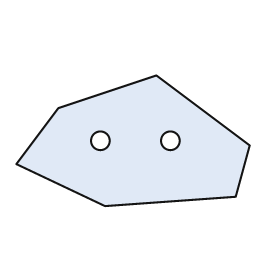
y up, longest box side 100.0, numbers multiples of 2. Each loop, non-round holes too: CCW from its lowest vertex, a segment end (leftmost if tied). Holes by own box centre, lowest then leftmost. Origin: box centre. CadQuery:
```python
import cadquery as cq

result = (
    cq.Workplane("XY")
    .moveTo(-12.0, -28.0)
    .lineTo(44.0, -24.0)
    .lineTo(50.0, -2.0)
    .lineTo(10.0, 28.0)
    .lineTo(-32.0, 14.0)
    .lineTo(-50.0, -10.0)
    .close()
    .moveTo(-14.0, 0.0)
    .circle(4.0)
    .moveTo(16.0, 0.0)
    .circle(4.0)
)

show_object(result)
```